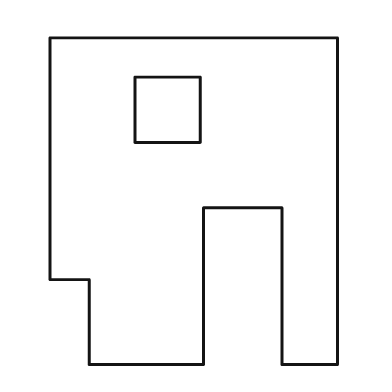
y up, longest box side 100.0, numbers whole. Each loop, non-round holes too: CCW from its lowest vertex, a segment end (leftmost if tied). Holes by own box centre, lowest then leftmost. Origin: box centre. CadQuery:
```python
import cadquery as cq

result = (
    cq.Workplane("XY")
    .moveTo(-32.0, -50.0)
    .lineTo(3.0, -50.0)
    .lineTo(3.0, -2.0)
    .lineTo(27.0, -2.0)
    .lineTo(27.0, -50.0)
    .lineTo(44.0, -50.0)
    .lineTo(44.0, 50.0)
    .lineTo(-44.0, 50.0)
    .lineTo(-44.0, -24.0)
    .lineTo(-32.0, -24.0)
    .close()
    .moveTo(-18.0, 18.0)
    .lineTo(2.0, 18.0)
    .lineTo(2.0, 38.0)
    .lineTo(-18.0, 38.0)
    .close()
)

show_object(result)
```